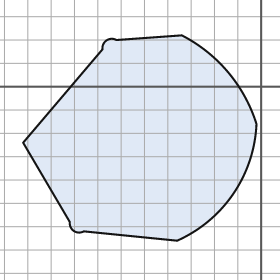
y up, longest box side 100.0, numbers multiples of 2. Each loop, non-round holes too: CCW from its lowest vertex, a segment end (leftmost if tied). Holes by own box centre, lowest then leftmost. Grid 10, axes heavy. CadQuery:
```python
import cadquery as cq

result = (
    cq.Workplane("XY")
    .moveTo(-36.0, -66.0)
    .threePointArc((-12.0, -46.0), (-2.0, -16.0))
    .threePointArc((-14.0, 6.0), (-34.0, 22.0))
    .lineTo(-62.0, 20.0)
    .threePointArc((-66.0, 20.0), (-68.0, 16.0))
    .lineTo(-102.0, -24.0)
    .lineTo(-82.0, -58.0)
    .threePointArc((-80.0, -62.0), (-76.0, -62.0))
    .close()
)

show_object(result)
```